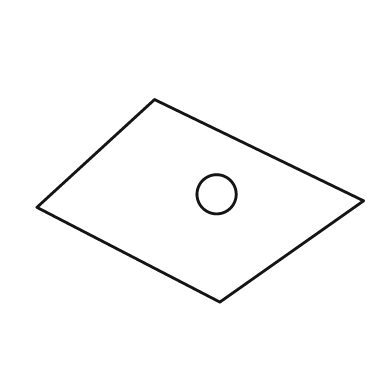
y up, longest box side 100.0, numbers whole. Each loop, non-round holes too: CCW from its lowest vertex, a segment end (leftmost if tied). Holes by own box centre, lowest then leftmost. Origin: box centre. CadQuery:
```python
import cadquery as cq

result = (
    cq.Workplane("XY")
    .moveTo(6.0, -31.0)
    .lineTo(50.0, 0.0)
    .lineTo(-14.0, 31.0)
    .lineTo(-50.0, -2.0)
    .close()
    .moveTo(5.0, 2.0)
    .circle(6.0)
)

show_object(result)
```